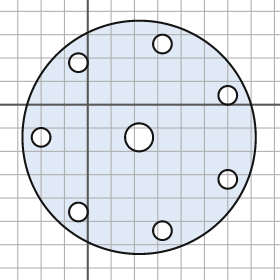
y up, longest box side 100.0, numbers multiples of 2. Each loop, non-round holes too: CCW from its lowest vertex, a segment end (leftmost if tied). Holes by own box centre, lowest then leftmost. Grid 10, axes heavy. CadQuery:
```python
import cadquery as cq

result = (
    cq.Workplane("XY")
    .moveTo(22.0, -14.0)
    .circle(50.0)
    .moveTo(32.0, -54.0)
    .circle(4.0)
    .moveTo(-4.0, -46.0)
    .circle(4.0)
    .moveTo(60.0, -32.0)
    .circle(4.0)
    .moveTo(-20.0, -14.0)
    .circle(4.0)
    .moveTo(22.0, -14.0)
    .circle(6.0)
    .moveTo(60.0, 4.0)
    .circle(4.0)
    .moveTo(-4.0, 18.0)
    .circle(4.0)
    .moveTo(32.0, 26.0)
    .circle(4.0)
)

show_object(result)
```